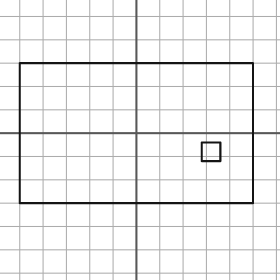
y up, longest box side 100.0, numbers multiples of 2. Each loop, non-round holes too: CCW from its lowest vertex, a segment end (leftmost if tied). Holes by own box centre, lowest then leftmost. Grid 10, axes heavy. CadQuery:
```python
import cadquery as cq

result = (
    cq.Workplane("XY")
    .moveTo(-50.0, -30.0)
    .lineTo(50.0, -30.0)
    .lineTo(50.0, 30.0)
    .lineTo(-50.0, 30.0)
    .close()
    .moveTo(28.0, -12.0)
    .lineTo(36.0, -12.0)
    .lineTo(36.0, -4.0)
    .lineTo(28.0, -4.0)
    .close()
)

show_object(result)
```